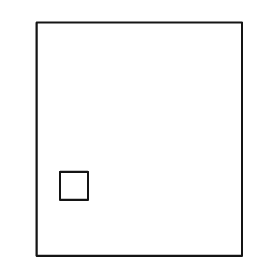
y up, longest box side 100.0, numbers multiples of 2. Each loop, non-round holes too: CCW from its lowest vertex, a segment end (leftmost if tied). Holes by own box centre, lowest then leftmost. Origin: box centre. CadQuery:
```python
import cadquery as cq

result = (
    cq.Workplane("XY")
    .moveTo(-44.0, -50.0)
    .lineTo(44.0, -50.0)
    .lineTo(44.0, 50.0)
    .lineTo(-44.0, 50.0)
    .close()
    .moveTo(-34.0, -26.0)
    .lineTo(-22.0, -26.0)
    .lineTo(-22.0, -14.0)
    .lineTo(-34.0, -14.0)
    .close()
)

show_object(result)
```